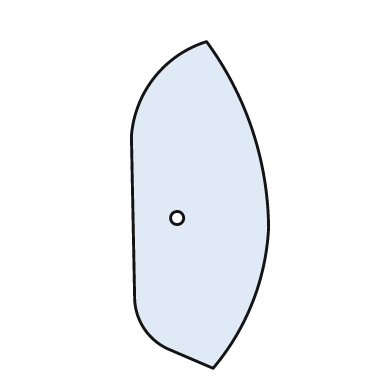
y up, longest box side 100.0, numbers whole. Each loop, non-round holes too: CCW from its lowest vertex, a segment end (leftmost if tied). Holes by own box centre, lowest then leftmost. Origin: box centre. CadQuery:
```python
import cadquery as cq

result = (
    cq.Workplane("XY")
    .moveTo(4.0, -50.0)
    .threePointArc((16.0, -30.0), (21.0, -7.0))
    .threePointArc((16.0, 23.0), (2.0, 50.0))
    .threePointArc((-14.0, 39.0), (-21.0, 21.0))
    .lineTo(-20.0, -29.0)
    .threePointArc((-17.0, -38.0), (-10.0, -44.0))
    .close()
    .moveTo(-7.0, -4.0)
    .circle(2.0)
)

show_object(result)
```